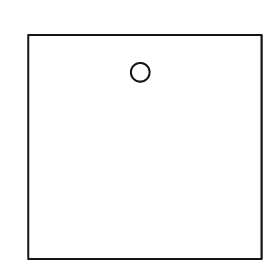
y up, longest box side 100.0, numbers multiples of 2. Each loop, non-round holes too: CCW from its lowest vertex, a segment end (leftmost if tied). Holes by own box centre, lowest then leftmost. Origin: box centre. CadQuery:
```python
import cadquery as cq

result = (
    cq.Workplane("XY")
    .moveTo(-50.0, -48.0)
    .lineTo(50.0, -48.0)
    .lineTo(50.0, 48.0)
    .lineTo(-50.0, 48.0)
    .close()
    .moveTo(-2.0, 32.0)
    .circle(4.0)
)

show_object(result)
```